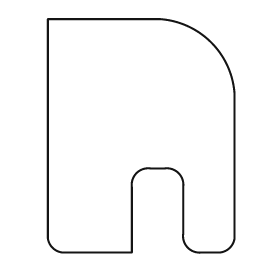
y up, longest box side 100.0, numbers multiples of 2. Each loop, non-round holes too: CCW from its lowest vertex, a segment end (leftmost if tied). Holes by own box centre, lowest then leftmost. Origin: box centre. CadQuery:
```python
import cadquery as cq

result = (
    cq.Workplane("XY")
    .moveTo(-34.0, -50.0)
    .lineTo(-4.0, -50.0)
    .lineTo(-4.0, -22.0)
    .threePointArc((-2.0, -16.0), (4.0, -14.0))
    .lineTo(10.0, -14.0)
    .threePointArc((16.0, -16.0), (18.0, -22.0))
    .lineTo(18.0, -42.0)
    .threePointArc((20.0, -48.0), (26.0, -50.0))
    .lineTo(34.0, -50.0)
    .threePointArc((38.0, -48.0), (40.0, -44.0))
    .lineTo(40.0, 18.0)
    .threePointArc((30.0, 40.0), (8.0, 50.0))
    .lineTo(-40.0, 50.0)
    .lineTo(-40.0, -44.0)
    .threePointArc((-38.0, -48.0), (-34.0, -50.0))
    .close()
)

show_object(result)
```